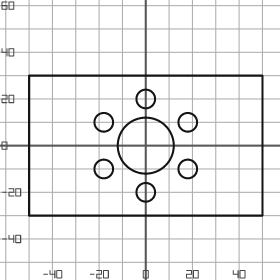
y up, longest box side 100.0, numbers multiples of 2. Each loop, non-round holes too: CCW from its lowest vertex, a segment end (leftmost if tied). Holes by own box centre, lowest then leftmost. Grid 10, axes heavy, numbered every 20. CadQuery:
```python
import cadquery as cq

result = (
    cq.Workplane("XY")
    .moveTo(-50.0, -30.0)
    .lineTo(50.0, -30.0)
    .lineTo(50.0, 30.0)
    .lineTo(-50.0, 30.0)
    .close()
    .moveTo(0.0, -20.0)
    .circle(4.0)
    .moveTo(-18.0, -10.0)
    .circle(4.0)
    .moveTo(18.0, -10.0)
    .circle(4.0)
    .moveTo(0.0, 0.0)
    .circle(12.0)
    .moveTo(-18.0, 10.0)
    .circle(4.0)
    .moveTo(18.0, 10.0)
    .circle(4.0)
    .moveTo(0.0, 20.0)
    .circle(4.0)
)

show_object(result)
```